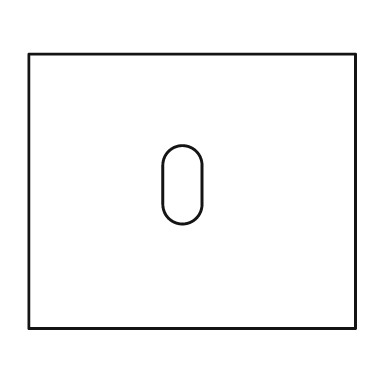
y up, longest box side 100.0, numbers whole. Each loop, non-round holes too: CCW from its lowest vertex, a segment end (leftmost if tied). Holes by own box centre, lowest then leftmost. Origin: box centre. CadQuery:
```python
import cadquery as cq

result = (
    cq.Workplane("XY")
    .moveTo(-50.0, -42.0)
    .lineTo(50.0, -42.0)
    .lineTo(50.0, 42.0)
    .lineTo(-50.0, 42.0)
    .close()
    .moveTo(-9.0, -4.0)
    .threePointArc((-3.0, -10.0), (3.0, -4.0))
    .lineTo(3.0, 8.0)
    .threePointArc((-3.0, 14.0), (-9.0, 8.0))
    .close()
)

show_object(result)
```